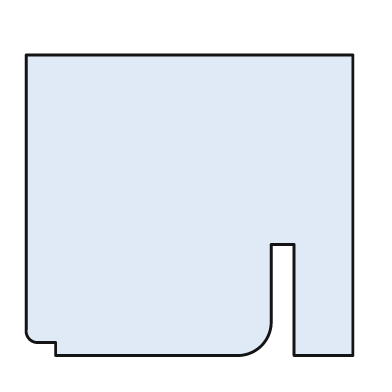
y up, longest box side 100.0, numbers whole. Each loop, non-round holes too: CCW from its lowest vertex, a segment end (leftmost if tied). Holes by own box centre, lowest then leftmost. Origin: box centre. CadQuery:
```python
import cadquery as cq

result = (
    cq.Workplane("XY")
    .moveTo(-41.0, -46.0)
    .lineTo(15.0, -46.0)
    .threePointArc((22.0, -43.0), (25.0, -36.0))
    .lineTo(25.0, -12.0)
    .lineTo(32.0, -12.0)
    .lineTo(32.0, -46.0)
    .lineTo(50.0, -46.0)
    .lineTo(50.0, 46.0)
    .lineTo(-50.0, 46.0)
    .lineTo(-50.0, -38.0)
    .threePointArc((-49.0, -41.0), (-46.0, -42.0))
    .lineTo(-41.0, -42.0)
    .close()
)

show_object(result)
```